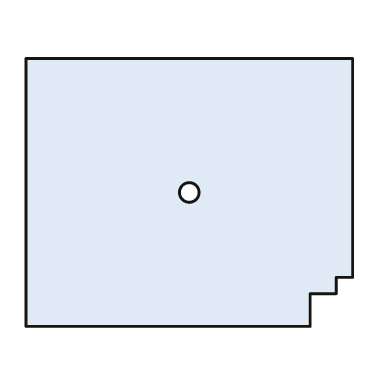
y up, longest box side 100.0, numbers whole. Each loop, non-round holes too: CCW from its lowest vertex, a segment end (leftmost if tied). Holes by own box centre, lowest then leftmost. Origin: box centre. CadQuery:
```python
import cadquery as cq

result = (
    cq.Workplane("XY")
    .moveTo(-50.0, -41.0)
    .lineTo(37.0, -41.0)
    .lineTo(37.0, -31.0)
    .lineTo(45.0, -31.0)
    .lineTo(45.0, -26.0)
    .lineTo(50.0, -26.0)
    .lineTo(50.0, 41.0)
    .lineTo(-50.0, 41.0)
    .close()
    .moveTo(0.0, 0.0)
    .circle(3.0)
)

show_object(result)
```